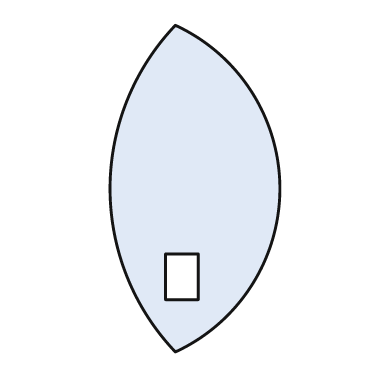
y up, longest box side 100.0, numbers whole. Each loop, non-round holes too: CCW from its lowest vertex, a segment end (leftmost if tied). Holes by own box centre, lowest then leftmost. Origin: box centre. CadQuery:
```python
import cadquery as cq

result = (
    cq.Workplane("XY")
    .moveTo(-6.0, -50.0)
    .threePointArc((26.0, 0.0), (-6.0, 50.0))
    .threePointArc((-26.0, 0.0), (-6.0, -50.0))
    .close()
    .moveTo(-9.0, -34.0)
    .lineTo(1.0, -34.0)
    .lineTo(1.0, -20.0)
    .lineTo(-9.0, -20.0)
    .close()
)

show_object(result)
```